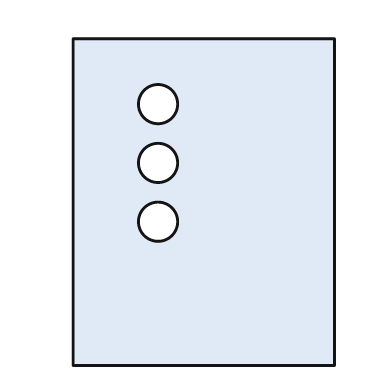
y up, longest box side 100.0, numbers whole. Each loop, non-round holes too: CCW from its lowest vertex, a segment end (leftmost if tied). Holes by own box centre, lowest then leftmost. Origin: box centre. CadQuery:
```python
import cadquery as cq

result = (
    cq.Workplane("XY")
    .moveTo(-40.0, -50.0)
    .lineTo(40.0, -50.0)
    .lineTo(40.0, 50.0)
    .lineTo(-40.0, 50.0)
    .close()
    .moveTo(-14.0, -6.0)
    .circle(6.0)
    .moveTo(-14.0, 12.0)
    .circle(6.0)
    .moveTo(-14.0, 30.0)
    .circle(6.0)
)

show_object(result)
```